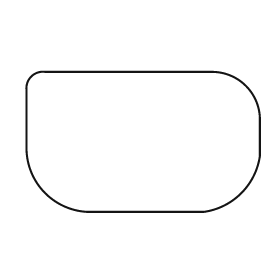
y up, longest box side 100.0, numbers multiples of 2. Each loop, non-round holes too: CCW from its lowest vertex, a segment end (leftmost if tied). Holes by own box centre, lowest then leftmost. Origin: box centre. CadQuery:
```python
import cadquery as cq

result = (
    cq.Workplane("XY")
    .moveTo(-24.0, -30.0)
    .lineTo(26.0, -30.0)
    .threePointArc((42.0, -22.0), (50.0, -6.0))
    .lineTo(50.0, 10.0)
    .threePointArc((44.0, 24.0), (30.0, 30.0))
    .lineTo(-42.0, 30.0)
    .threePointArc((-48.0, 28.0), (-50.0, 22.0))
    .lineTo(-50.0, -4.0)
    .threePointArc((-42.0, -22.0), (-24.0, -30.0))
    .close()
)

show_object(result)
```